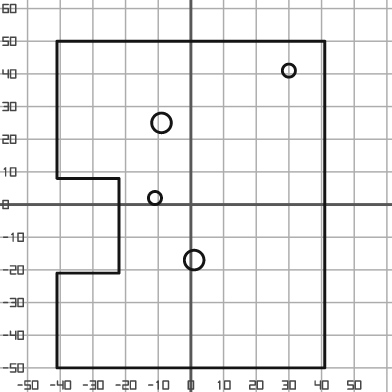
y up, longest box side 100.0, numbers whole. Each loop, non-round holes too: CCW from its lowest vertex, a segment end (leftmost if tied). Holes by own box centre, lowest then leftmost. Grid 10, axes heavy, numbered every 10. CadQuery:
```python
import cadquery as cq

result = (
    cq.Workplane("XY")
    .moveTo(-41.0, -50.0)
    .lineTo(41.0, -50.0)
    .lineTo(41.0, 50.0)
    .lineTo(-41.0, 50.0)
    .lineTo(-41.0, 8.0)
    .lineTo(-22.0, 8.0)
    .lineTo(-22.0, -21.0)
    .lineTo(-41.0, -21.0)
    .close()
    .moveTo(1.0, -17.0)
    .circle(3.0)
    .moveTo(-11.0, 2.0)
    .circle(2.0)
    .moveTo(-9.0, 25.0)
    .circle(3.0)
    .moveTo(30.0, 41.0)
    .circle(2.0)
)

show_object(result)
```